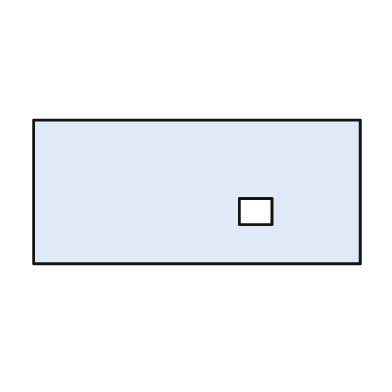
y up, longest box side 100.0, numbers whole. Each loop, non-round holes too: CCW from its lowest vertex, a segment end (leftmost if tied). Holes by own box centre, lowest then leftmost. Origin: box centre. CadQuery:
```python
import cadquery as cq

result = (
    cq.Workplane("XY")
    .moveTo(-50.0, -22.0)
    .lineTo(50.0, -22.0)
    .lineTo(50.0, 22.0)
    .lineTo(-50.0, 22.0)
    .close()
    .moveTo(13.0, -10.0)
    .lineTo(23.0, -10.0)
    .lineTo(23.0, -2.0)
    .lineTo(13.0, -2.0)
    .close()
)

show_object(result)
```